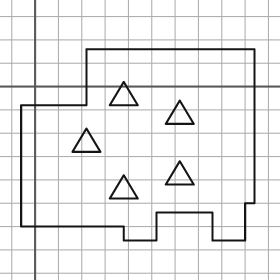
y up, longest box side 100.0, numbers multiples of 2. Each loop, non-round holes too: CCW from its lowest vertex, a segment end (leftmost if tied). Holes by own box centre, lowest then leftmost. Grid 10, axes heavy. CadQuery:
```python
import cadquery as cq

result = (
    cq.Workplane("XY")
    .moveTo(38.0, -66.0)
    .lineTo(52.0, -66.0)
    .lineTo(52.0, -54.0)
    .lineTo(76.0, -54.0)
    .lineTo(76.0, -66.0)
    .lineTo(90.0, -66.0)
    .lineTo(90.0, -50.0)
    .lineTo(94.0, -50.0)
    .lineTo(94.0, 16.0)
    .lineTo(22.0, 16.0)
    .lineTo(22.0, -8.0)
    .lineTo(-6.0, -8.0)
    .lineTo(-6.0, -60.0)
    .lineTo(38.0, -60.0)
    .close()
    .moveTo(32.0, -48.0)
    .lineTo(44.0, -48.0)
    .lineTo(38.0, -38.0)
    .close()
    .moveTo(56.0, -42.0)
    .lineTo(68.0, -42.0)
    .lineTo(62.0, -32.0)
    .close()
    .moveTo(16.0, -28.0)
    .lineTo(28.0, -28.0)
    .lineTo(22.0, -18.0)
    .close()
    .moveTo(56.0, -16.0)
    .lineTo(68.0, -16.0)
    .lineTo(62.0, -6.0)
    .close()
    .moveTo(32.0, -8.0)
    .lineTo(44.0, -8.0)
    .lineTo(38.0, 2.0)
    .close()
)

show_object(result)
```